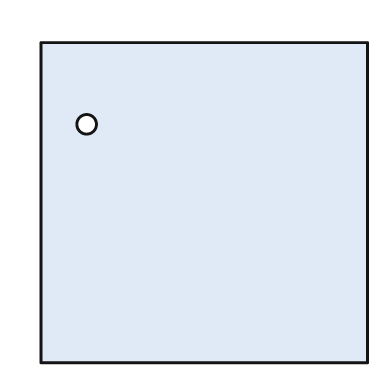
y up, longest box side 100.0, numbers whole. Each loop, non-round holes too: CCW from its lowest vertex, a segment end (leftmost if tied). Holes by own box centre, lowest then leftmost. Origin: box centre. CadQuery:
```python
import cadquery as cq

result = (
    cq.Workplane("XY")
    .moveTo(-50.0, -49.0)
    .lineTo(50.0, -49.0)
    .lineTo(50.0, 49.0)
    .lineTo(-50.0, 49.0)
    .close()
    .moveTo(-36.0, 24.0)
    .circle(3.0)
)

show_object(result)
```